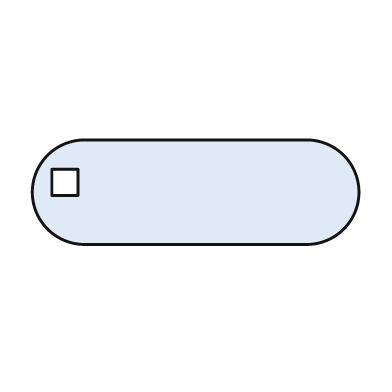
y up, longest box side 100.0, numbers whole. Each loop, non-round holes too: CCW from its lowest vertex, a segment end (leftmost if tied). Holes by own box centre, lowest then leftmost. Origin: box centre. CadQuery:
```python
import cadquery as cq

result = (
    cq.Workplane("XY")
    .moveTo(-34.0, -16.0)
    .lineTo(34.0, -16.0)
    .threePointArc((50.0, 0.0), (34.0, 16.0))
    .lineTo(-34.0, 16.0)
    .threePointArc((-50.0, 0.0), (-34.0, -16.0))
    .close()
    .moveTo(-44.0, -1.0)
    .lineTo(-36.0, -1.0)
    .lineTo(-36.0, 7.0)
    .lineTo(-44.0, 7.0)
    .close()
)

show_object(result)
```